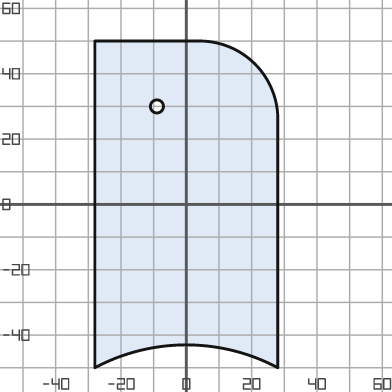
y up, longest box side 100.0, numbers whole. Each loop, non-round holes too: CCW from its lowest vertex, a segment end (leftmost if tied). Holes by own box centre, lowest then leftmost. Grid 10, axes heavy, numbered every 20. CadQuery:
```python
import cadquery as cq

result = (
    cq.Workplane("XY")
    .moveTo(-28.0, -50.0)
    .threePointArc((0.0, -43.0), (28.0, -50.0))
    .lineTo(28.0, 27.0)
    .threePointArc((21.0, 43.0), (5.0, 50.0))
    .lineTo(-28.0, 50.0)
    .close()
    .moveTo(-9.0, 30.0)
    .circle(2.0)
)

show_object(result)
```